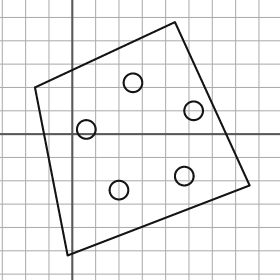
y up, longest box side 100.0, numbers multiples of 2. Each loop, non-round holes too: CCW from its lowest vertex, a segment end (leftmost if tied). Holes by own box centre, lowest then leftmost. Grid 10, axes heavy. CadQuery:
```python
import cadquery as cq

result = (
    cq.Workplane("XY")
    .moveTo(-2.0, -52.0)
    .lineTo(76.0, -22.0)
    .lineTo(44.0, 48.0)
    .lineTo(-16.0, 20.0)
    .close()
    .moveTo(20.0, -24.0)
    .circle(4.0)
    .moveTo(48.0, -18.0)
    .circle(4.0)
    .moveTo(6.0, 2.0)
    .circle(4.0)
    .moveTo(52.0, 10.0)
    .circle(4.0)
    .moveTo(26.0, 22.0)
    .circle(4.0)
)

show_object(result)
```